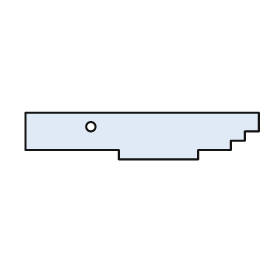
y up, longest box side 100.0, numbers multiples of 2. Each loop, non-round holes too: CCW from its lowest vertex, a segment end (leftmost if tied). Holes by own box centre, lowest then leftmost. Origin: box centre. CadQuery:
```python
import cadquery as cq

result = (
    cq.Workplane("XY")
    .moveTo(-10.0, -10.0)
    .lineTo(24.0, -10.0)
    .lineTo(24.0, -6.0)
    .lineTo(38.0, -6.0)
    .lineTo(38.0, -2.0)
    .lineTo(44.0, -2.0)
    .lineTo(44.0, 2.0)
    .lineTo(50.0, 2.0)
    .lineTo(50.0, 10.0)
    .lineTo(-50.0, 10.0)
    .lineTo(-50.0, -6.0)
    .lineTo(-10.0, -6.0)
    .close()
    .moveTo(-22.0, 4.0)
    .circle(2.0)
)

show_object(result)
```